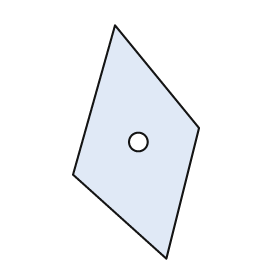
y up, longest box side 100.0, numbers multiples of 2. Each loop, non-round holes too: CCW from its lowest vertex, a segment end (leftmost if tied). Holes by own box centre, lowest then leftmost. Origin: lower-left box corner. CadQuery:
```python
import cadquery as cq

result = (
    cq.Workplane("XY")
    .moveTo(40.0, 0.0)
    .lineTo(54.0, 56.0)
    .lineTo(18.0, 100.0)
    .lineTo(0.0, 36.0)
    .close()
    .moveTo(28.0, 50.0)
    .circle(4.0)
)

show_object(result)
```